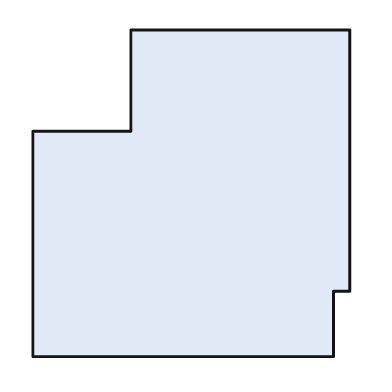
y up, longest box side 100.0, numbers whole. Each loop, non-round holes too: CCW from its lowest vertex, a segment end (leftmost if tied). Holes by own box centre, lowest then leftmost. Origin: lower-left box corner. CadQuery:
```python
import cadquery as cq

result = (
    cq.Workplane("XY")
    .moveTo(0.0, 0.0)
    .lineTo(92.0, 0.0)
    .lineTo(92.0, 20.0)
    .lineTo(97.0, 20.0)
    .lineTo(97.0, 100.0)
    .lineTo(30.0, 100.0)
    .lineTo(30.0, 69.0)
    .lineTo(0.0, 69.0)
    .close()
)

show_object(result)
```